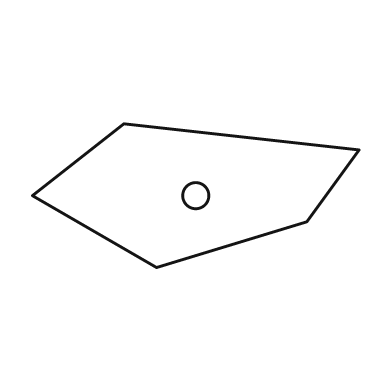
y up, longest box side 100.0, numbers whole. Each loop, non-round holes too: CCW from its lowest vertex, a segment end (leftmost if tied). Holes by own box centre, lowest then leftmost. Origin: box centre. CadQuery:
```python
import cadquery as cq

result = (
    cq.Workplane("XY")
    .moveTo(-12.0, -22.0)
    .lineTo(34.0, -8.0)
    .lineTo(50.0, 14.0)
    .lineTo(-22.0, 22.0)
    .lineTo(-50.0, 0.0)
    .close()
    .moveTo(0.0, 0.0)
    .circle(4.0)
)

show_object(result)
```